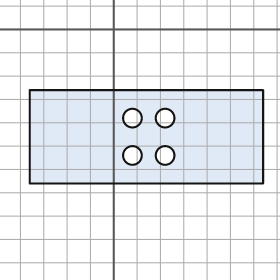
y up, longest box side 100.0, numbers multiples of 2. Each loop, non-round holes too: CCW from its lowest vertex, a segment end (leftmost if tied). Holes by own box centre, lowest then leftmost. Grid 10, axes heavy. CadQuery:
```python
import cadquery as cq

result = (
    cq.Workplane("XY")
    .moveTo(-36.0, -66.0)
    .lineTo(64.0, -66.0)
    .lineTo(64.0, -26.0)
    .lineTo(-36.0, -26.0)
    .close()
    .moveTo(8.0, -54.0)
    .circle(4.0)
    .moveTo(22.0, -54.0)
    .circle(4.0)
    .moveTo(8.0, -38.0)
    .circle(4.0)
    .moveTo(22.0, -38.0)
    .circle(4.0)
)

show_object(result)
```